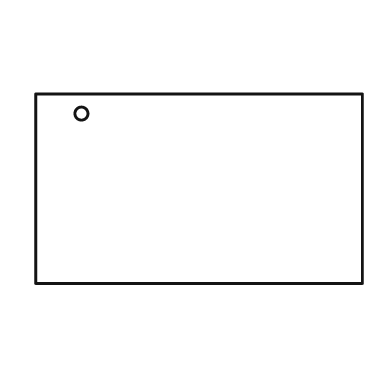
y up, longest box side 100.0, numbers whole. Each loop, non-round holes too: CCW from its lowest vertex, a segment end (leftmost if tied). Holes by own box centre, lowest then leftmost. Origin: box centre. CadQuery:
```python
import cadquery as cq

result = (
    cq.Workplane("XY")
    .moveTo(-50.0, -29.0)
    .lineTo(50.0, -29.0)
    .lineTo(50.0, 29.0)
    .lineTo(-50.0, 29.0)
    .close()
    .moveTo(-36.0, 23.0)
    .circle(2.0)
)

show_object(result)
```